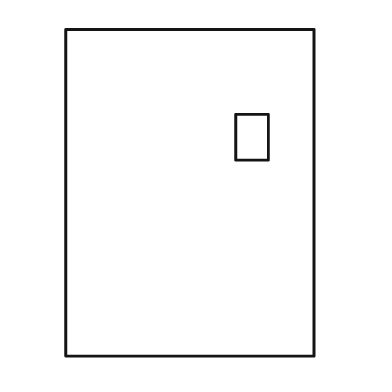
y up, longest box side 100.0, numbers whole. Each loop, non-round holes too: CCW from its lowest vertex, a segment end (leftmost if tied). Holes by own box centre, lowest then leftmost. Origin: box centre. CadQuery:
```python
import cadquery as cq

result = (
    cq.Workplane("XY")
    .moveTo(-38.0, -50.0)
    .lineTo(38.0, -50.0)
    .lineTo(38.0, 50.0)
    .lineTo(-38.0, 50.0)
    .close()
    .moveTo(14.0, 10.0)
    .lineTo(24.0, 10.0)
    .lineTo(24.0, 24.0)
    .lineTo(14.0, 24.0)
    .close()
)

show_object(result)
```